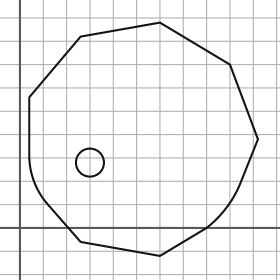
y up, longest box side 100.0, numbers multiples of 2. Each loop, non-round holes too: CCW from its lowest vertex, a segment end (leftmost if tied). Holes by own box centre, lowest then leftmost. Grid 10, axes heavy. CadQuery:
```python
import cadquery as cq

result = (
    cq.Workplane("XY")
    .moveTo(60.0, -12.0)
    .lineTo(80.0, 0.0)
    .threePointArc((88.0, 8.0), (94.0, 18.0))
    .lineTo(102.0, 38.0)
    .lineTo(90.0, 70.0)
    .lineTo(60.0, 88.0)
    .lineTo(26.0, 82.0)
    .lineTo(4.0, 56.0)
    .lineTo(4.0, 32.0)
    .threePointArc((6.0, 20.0), (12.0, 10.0))
    .lineTo(26.0, -6.0)
    .close()
    .moveTo(30.0, 28.0)
    .circle(6.0)
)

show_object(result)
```